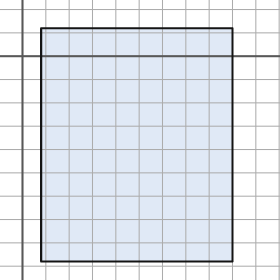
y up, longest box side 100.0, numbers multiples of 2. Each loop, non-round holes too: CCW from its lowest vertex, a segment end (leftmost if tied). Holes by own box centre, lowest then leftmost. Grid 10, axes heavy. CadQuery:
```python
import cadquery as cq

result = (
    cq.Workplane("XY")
    .moveTo(8.0, -88.0)
    .lineTo(90.0, -88.0)
    .lineTo(90.0, 12.0)
    .lineTo(8.0, 12.0)
    .close()
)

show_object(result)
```